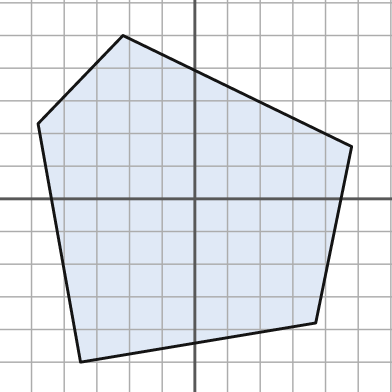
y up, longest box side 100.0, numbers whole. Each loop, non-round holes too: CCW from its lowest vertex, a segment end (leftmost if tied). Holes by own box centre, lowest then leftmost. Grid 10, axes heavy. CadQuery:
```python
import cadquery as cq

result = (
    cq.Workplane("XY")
    .moveTo(-35.0, -50.0)
    .lineTo(37.0, -38.0)
    .lineTo(48.0, 16.0)
    .lineTo(-22.0, 50.0)
    .lineTo(-48.0, 23.0)
    .close()
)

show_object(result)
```